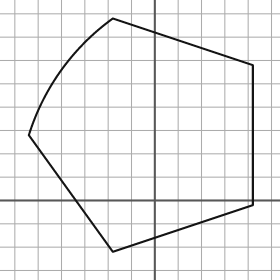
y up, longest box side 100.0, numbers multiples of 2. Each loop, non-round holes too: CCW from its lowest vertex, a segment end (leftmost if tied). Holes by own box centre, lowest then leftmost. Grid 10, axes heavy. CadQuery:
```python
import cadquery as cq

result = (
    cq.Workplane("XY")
    .moveTo(-18.0, -22.0)
    .lineTo(42.0, -2.0)
    .lineTo(42.0, 58.0)
    .lineTo(-18.0, 78.0)
    .threePointArc((-40.0, 56.0), (-54.0, 28.0))
    .close()
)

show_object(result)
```